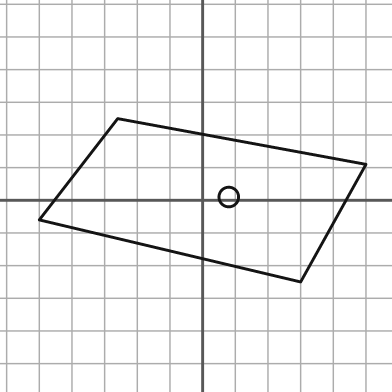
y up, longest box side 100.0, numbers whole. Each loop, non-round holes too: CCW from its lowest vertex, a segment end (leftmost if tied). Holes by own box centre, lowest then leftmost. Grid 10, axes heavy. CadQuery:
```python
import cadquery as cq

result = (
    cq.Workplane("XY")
    .moveTo(30.0, -25.0)
    .lineTo(50.0, 11.0)
    .lineTo(-26.0, 25.0)
    .lineTo(-50.0, -6.0)
    .close()
    .moveTo(8.0, 1.0)
    .circle(3.0)
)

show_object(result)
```